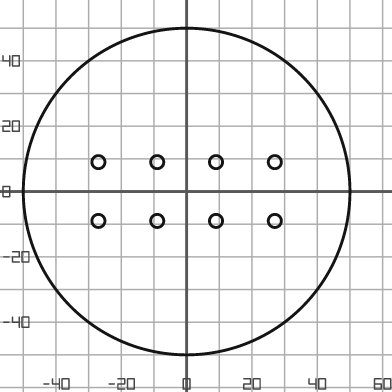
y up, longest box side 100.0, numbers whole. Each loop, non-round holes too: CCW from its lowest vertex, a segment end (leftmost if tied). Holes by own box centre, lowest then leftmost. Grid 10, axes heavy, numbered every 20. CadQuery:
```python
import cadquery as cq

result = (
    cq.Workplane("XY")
    .moveTo(0.0, 0.0)
    .circle(50.0)
    .moveTo(-27.0, -9.0)
    .circle(2.0)
    .moveTo(-9.0, -9.0)
    .circle(2.0)
    .moveTo(9.0, -9.0)
    .circle(2.0)
    .moveTo(27.0, -9.0)
    .circle(2.0)
    .moveTo(-27.0, 9.0)
    .circle(2.0)
    .moveTo(-9.0, 9.0)
    .circle(2.0)
    .moveTo(9.0, 9.0)
    .circle(2.0)
    .moveTo(27.0, 9.0)
    .circle(2.0)
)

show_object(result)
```